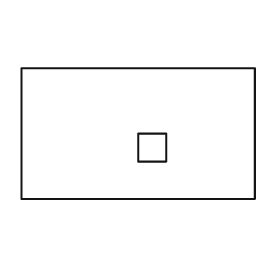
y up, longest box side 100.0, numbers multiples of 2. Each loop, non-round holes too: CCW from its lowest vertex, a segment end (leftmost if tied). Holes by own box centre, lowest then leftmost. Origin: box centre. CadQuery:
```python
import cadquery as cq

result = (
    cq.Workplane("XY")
    .moveTo(-50.0, -28.0)
    .lineTo(50.0, -28.0)
    .lineTo(50.0, 28.0)
    .lineTo(-50.0, 28.0)
    .close()
    .moveTo(0.0, -12.0)
    .lineTo(12.0, -12.0)
    .lineTo(12.0, 0.0)
    .lineTo(0.0, 0.0)
    .close()
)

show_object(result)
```